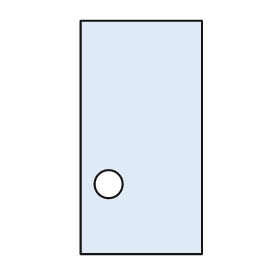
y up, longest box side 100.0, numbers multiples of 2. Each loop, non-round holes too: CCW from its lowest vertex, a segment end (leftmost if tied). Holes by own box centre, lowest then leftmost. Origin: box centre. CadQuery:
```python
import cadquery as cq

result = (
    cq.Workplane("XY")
    .moveTo(-26.0, -50.0)
    .lineTo(26.0, -50.0)
    .lineTo(26.0, 50.0)
    .lineTo(-26.0, 50.0)
    .close()
    .moveTo(-14.0, -20.0)
    .circle(6.0)
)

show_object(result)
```